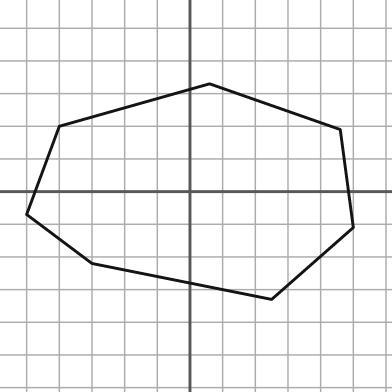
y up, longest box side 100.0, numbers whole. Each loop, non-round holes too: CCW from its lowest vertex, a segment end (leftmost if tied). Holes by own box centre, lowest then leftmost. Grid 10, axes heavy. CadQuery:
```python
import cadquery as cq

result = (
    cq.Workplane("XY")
    .moveTo(25.0, -33.0)
    .lineTo(50.0, -11.0)
    .lineTo(46.0, 19.0)
    .lineTo(6.0, 33.0)
    .lineTo(-40.0, 20.0)
    .lineTo(-50.0, -7.0)
    .lineTo(-30.0, -22.0)
    .close()
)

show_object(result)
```